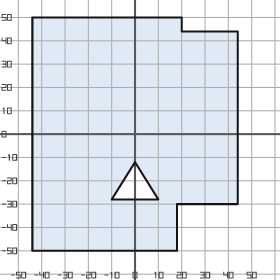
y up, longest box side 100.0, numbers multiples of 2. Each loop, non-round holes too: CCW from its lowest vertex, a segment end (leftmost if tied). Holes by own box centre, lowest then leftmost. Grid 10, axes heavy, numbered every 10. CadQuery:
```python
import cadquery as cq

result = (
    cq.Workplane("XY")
    .moveTo(-44.0, -50.0)
    .lineTo(18.0, -50.0)
    .lineTo(18.0, -30.0)
    .lineTo(44.0, -30.0)
    .lineTo(44.0, 44.0)
    .lineTo(20.0, 44.0)
    .lineTo(20.0, 50.0)
    .lineTo(-44.0, 50.0)
    .close()
    .moveTo(-10.0, -28.0)
    .lineTo(10.0, -28.0)
    .lineTo(0.0, -12.0)
    .close()
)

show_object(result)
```